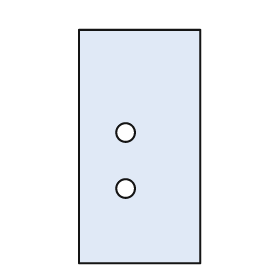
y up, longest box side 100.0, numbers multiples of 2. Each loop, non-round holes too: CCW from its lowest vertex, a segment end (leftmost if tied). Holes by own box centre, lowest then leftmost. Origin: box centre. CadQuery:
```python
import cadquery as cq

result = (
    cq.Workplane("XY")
    .moveTo(-26.0, -50.0)
    .lineTo(26.0, -50.0)
    .lineTo(26.0, 50.0)
    .lineTo(-26.0, 50.0)
    .close()
    .moveTo(-6.0, -18.0)
    .circle(4.0)
    .moveTo(-6.0, 6.0)
    .circle(4.0)
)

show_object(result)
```